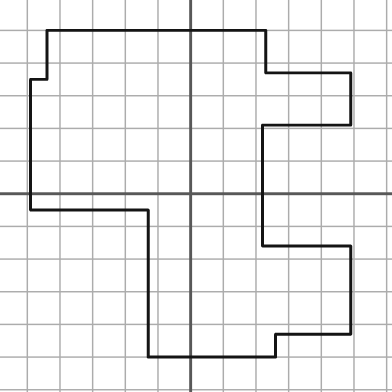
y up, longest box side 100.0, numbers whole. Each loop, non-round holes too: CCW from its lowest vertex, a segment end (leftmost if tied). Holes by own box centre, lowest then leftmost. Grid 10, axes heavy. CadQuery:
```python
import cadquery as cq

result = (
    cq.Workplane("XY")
    .moveTo(-13.0, -50.0)
    .lineTo(26.0, -50.0)
    .lineTo(26.0, -43.0)
    .lineTo(49.0, -43.0)
    .lineTo(49.0, -16.0)
    .lineTo(22.0, -16.0)
    .lineTo(22.0, 21.0)
    .lineTo(49.0, 21.0)
    .lineTo(49.0, 37.0)
    .lineTo(23.0, 37.0)
    .lineTo(23.0, 50.0)
    .lineTo(-44.0, 50.0)
    .lineTo(-44.0, 35.0)
    .lineTo(-49.0, 35.0)
    .lineTo(-49.0, -5.0)
    .lineTo(-13.0, -5.0)
    .close()
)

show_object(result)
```